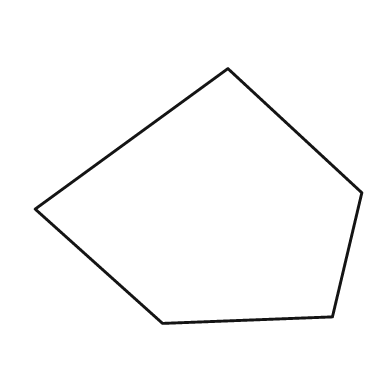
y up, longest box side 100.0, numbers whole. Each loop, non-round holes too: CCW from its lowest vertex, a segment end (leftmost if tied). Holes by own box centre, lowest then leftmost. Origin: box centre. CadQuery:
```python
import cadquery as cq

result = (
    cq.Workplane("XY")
    .moveTo(-11.0, -39.0)
    .lineTo(41.0, -37.0)
    .lineTo(50.0, 1.0)
    .lineTo(9.0, 39.0)
    .lineTo(-50.0, -4.0)
    .close()
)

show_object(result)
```